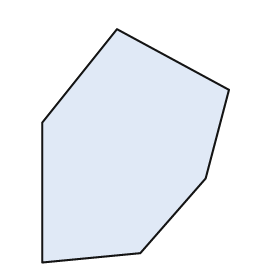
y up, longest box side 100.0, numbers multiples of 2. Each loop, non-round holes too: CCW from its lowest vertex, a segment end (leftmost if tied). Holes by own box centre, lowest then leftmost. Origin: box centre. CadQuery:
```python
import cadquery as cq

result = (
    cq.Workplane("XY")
    .moveTo(-40.0, -50.0)
    .lineTo(2.0, -46.0)
    .lineTo(30.0, -14.0)
    .lineTo(40.0, 24.0)
    .lineTo(-8.0, 50.0)
    .lineTo(-40.0, 10.0)
    .close()
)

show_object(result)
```